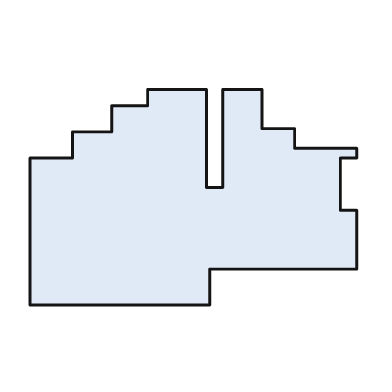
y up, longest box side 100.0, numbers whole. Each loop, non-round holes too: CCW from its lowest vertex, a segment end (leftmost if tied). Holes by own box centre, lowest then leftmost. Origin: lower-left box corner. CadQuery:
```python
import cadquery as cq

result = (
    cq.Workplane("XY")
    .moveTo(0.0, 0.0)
    .lineTo(55.0, 0.0)
    .lineTo(55.0, 11.0)
    .lineTo(100.0, 11.0)
    .lineTo(100.0, 29.0)
    .lineTo(95.0, 29.0)
    .lineTo(95.0, 45.0)
    .lineTo(100.0, 45.0)
    .lineTo(100.0, 48.0)
    .lineTo(81.0, 48.0)
    .lineTo(81.0, 54.0)
    .lineTo(71.0, 54.0)
    .lineTo(71.0, 66.0)
    .lineTo(59.0, 66.0)
    .lineTo(59.0, 36.0)
    .lineTo(54.0, 36.0)
    .lineTo(54.0, 66.0)
    .lineTo(36.0, 66.0)
    .lineTo(36.0, 61.0)
    .lineTo(25.0, 61.0)
    .lineTo(25.0, 53.0)
    .lineTo(13.0, 53.0)
    .lineTo(13.0, 45.0)
    .lineTo(0.0, 45.0)
    .close()
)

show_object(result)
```